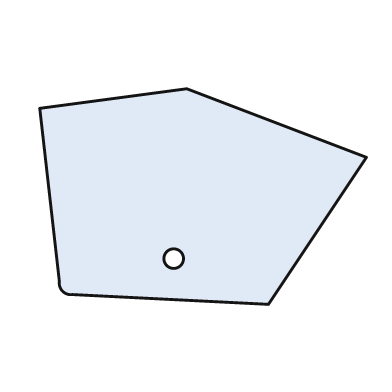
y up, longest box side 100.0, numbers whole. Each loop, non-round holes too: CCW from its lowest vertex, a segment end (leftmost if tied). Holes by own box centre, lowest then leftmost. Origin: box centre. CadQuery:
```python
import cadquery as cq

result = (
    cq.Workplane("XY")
    .moveTo(20.0, -33.0)
    .lineTo(50.0, 12.0)
    .lineTo(-5.0, 33.0)
    .lineTo(-50.0, 27.0)
    .lineTo(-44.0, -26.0)
    .threePointArc((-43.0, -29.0), (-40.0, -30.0))
    .close()
    .moveTo(-9.0, -19.0)
    .circle(3.0)
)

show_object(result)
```